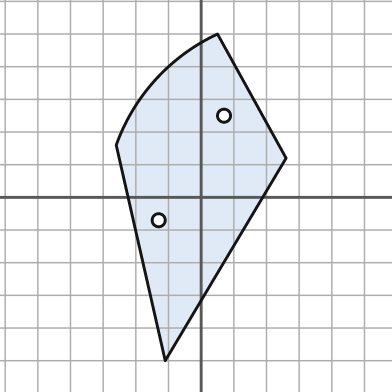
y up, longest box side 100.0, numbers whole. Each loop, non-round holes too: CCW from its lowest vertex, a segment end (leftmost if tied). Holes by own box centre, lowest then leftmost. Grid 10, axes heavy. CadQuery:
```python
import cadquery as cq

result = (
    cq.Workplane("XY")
    .moveTo(-11.0, -50.0)
    .lineTo(26.0, 12.0)
    .lineTo(5.0, 50.0)
    .threePointArc((-14.0, 36.0), (-26.0, 16.0))
    .close()
    .moveTo(-13.0, -7.0)
    .circle(2.0)
    .moveTo(7.0, 25.0)
    .circle(2.0)
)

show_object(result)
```